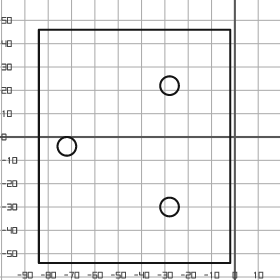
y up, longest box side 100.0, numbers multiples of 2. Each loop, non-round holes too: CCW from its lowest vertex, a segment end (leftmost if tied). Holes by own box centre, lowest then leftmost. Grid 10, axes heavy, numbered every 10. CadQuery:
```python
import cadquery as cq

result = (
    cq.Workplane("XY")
    .moveTo(-84.0, -54.0)
    .lineTo(-2.0, -54.0)
    .lineTo(-2.0, 46.0)
    .lineTo(-84.0, 46.0)
    .close()
    .moveTo(-28.0, -30.0)
    .circle(4.0)
    .moveTo(-72.0, -4.0)
    .circle(4.0)
    .moveTo(-28.0, 22.0)
    .circle(4.0)
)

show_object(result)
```